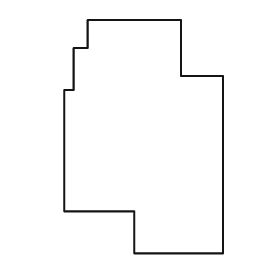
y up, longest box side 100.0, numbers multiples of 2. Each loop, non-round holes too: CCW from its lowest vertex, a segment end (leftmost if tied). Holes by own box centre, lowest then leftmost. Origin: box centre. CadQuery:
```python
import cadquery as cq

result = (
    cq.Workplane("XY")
    .moveTo(-4.0, -50.0)
    .lineTo(34.0, -50.0)
    .lineTo(34.0, 26.0)
    .lineTo(16.0, 26.0)
    .lineTo(16.0, 50.0)
    .lineTo(-24.0, 50.0)
    .lineTo(-24.0, 38.0)
    .lineTo(-30.0, 38.0)
    .lineTo(-30.0, 20.0)
    .lineTo(-34.0, 20.0)
    .lineTo(-34.0, -32.0)
    .lineTo(-4.0, -32.0)
    .close()
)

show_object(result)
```